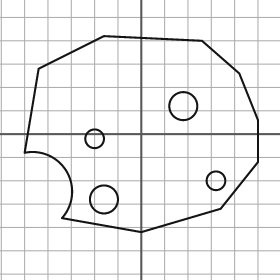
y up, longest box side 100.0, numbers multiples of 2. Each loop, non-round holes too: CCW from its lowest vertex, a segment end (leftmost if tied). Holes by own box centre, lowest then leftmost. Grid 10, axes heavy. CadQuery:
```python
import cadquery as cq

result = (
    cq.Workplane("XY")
    .moveTo(0.0, -42.0)
    .lineTo(34.0, -32.0)
    .lineTo(50.0, -12.0)
    .lineTo(50.0, 6.0)
    .lineTo(42.0, 26.0)
    .lineTo(26.0, 40.0)
    .lineTo(-16.0, 42.0)
    .lineTo(-44.0, 28.0)
    .lineTo(-50.0, -8.0)
    .threePointArc((-32.0, -16.0), (-34.0, -36.0))
    .close()
    .moveTo(-16.0, -28.0)
    .circle(6.0)
    .moveTo(32.0, -20.0)
    .circle(4.0)
    .moveTo(-20.0, -2.0)
    .circle(4.0)
    .moveTo(18.0, 12.0)
    .circle(6.0)
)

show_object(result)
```